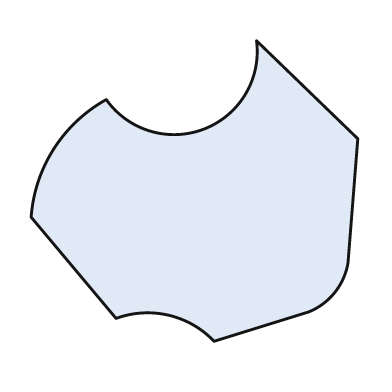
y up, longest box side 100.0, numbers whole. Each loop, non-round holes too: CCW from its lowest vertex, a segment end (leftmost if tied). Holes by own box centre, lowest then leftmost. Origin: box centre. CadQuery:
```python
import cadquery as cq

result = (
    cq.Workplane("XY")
    .moveTo(6.0, -46.0)
    .lineTo(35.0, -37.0)
    .threePointArc((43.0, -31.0), (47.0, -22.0))
    .lineTo(50.0, 16.0)
    .lineTo(19.0, 46.0)
    .threePointArc((3.0, 19.0), (-27.0, 28.0))
    .threePointArc((-43.0, 13.0), (-50.0, -8.0))
    .lineTo(-24.0, -39.0)
    .threePointArc((-8.0, -38.0), (6.0, -46.0))
    .close()
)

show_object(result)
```